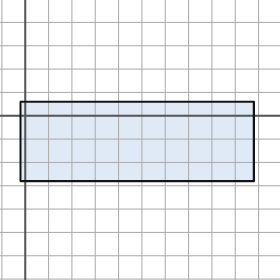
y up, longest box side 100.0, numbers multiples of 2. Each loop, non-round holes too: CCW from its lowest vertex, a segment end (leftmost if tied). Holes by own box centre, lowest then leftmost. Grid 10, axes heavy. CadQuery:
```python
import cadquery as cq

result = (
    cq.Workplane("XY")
    .moveTo(-2.0, -28.0)
    .lineTo(98.0, -28.0)
    .lineTo(98.0, 6.0)
    .lineTo(-2.0, 6.0)
    .close()
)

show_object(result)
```